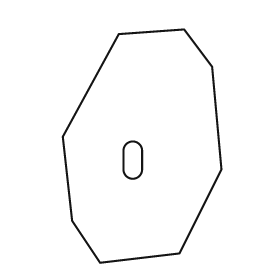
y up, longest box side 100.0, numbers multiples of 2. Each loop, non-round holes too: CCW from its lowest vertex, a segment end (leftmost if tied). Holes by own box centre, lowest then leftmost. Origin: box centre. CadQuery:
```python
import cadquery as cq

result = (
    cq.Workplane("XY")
    .moveTo(-18.0, -50.0)
    .lineTo(16.0, -46.0)
    .lineTo(34.0, -10.0)
    .lineTo(30.0, 34.0)
    .lineTo(18.0, 50.0)
    .lineTo(-10.0, 48.0)
    .lineTo(-34.0, 4.0)
    .lineTo(-30.0, -32.0)
    .close()
    .moveTo(-8.0, -10.0)
    .threePointArc((-4.0, -14.0), (0.0, -10.0))
    .lineTo(0.0, -2.0)
    .threePointArc((-4.0, 2.0), (-8.0, -2.0))
    .close()
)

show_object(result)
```